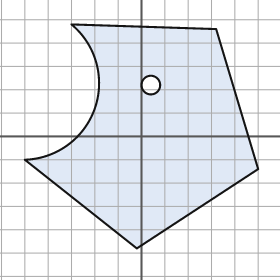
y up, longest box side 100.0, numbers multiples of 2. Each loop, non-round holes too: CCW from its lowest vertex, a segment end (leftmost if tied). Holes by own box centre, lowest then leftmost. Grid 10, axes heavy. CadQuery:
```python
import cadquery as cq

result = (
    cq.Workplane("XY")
    .moveTo(-2.0, -48.0)
    .lineTo(50.0, -14.0)
    .lineTo(32.0, 46.0)
    .lineTo(-30.0, 48.0)
    .threePointArc((-20.0, 12.0), (-50.0, -10.0))
    .close()
    .moveTo(4.0, 22.0)
    .circle(4.0)
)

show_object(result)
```